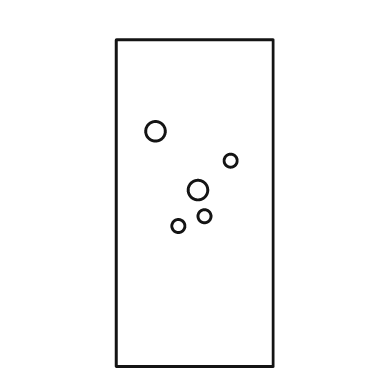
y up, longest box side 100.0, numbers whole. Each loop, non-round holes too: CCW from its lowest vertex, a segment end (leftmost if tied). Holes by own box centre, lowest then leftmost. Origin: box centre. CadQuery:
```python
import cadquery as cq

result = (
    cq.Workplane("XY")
    .moveTo(-24.0, -50.0)
    .lineTo(24.0, -50.0)
    .lineTo(24.0, 50.0)
    .lineTo(-24.0, 50.0)
    .close()
    .moveTo(-5.0, -7.0)
    .circle(2.0)
    .moveTo(3.0, -4.0)
    .circle(2.0)
    .moveTo(1.0, 4.0)
    .circle(3.0)
    .moveTo(11.0, 13.0)
    .circle(2.0)
    .moveTo(-12.0, 22.0)
    .circle(3.0)
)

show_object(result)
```